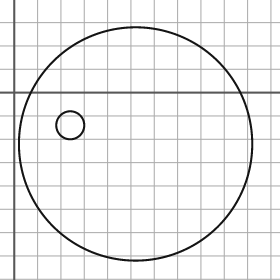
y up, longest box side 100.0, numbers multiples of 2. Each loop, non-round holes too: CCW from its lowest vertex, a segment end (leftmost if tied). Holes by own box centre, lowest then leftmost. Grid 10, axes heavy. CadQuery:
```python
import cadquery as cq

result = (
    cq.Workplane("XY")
    .moveTo(52.0, -22.0)
    .circle(50.0)
    .moveTo(24.0, -14.0)
    .circle(6.0)
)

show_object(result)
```